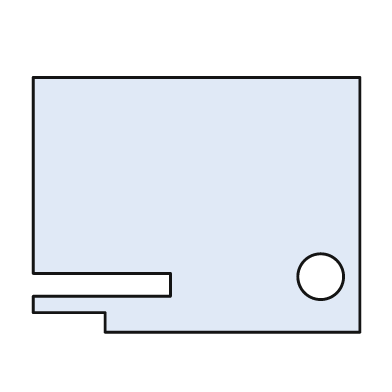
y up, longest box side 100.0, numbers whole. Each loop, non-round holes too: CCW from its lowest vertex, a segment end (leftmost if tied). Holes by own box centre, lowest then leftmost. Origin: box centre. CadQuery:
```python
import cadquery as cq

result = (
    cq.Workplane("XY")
    .moveTo(-28.0, -39.0)
    .lineTo(50.0, -39.0)
    .lineTo(50.0, 39.0)
    .lineTo(-50.0, 39.0)
    .lineTo(-50.0, -21.0)
    .lineTo(-8.0, -21.0)
    .lineTo(-8.0, -28.0)
    .lineTo(-50.0, -28.0)
    .lineTo(-50.0, -33.0)
    .lineTo(-28.0, -33.0)
    .close()
    .moveTo(38.0, -22.0)
    .circle(7.0)
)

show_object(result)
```